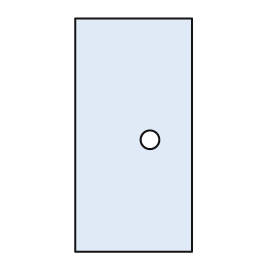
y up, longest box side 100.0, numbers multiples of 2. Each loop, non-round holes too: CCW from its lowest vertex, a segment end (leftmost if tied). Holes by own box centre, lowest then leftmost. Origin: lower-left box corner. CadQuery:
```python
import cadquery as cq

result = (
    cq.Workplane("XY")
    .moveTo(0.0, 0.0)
    .lineTo(50.0, 0.0)
    .lineTo(50.0, 100.0)
    .lineTo(0.0, 100.0)
    .close()
    .moveTo(32.0, 48.0)
    .circle(4.0)
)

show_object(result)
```